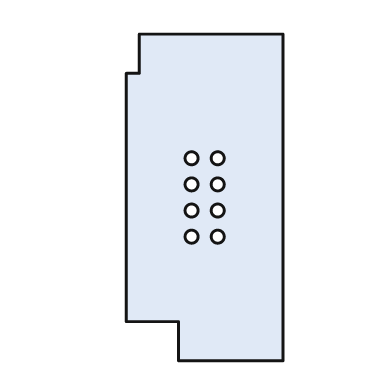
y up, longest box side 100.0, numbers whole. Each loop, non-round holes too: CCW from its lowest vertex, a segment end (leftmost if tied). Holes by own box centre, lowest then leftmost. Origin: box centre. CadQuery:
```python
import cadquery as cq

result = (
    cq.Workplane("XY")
    .moveTo(-8.0, -50.0)
    .lineTo(24.0, -50.0)
    .lineTo(24.0, 50.0)
    .lineTo(-20.0, 50.0)
    .lineTo(-20.0, 38.0)
    .lineTo(-24.0, 38.0)
    .lineTo(-24.0, -38.0)
    .lineTo(-8.0, -38.0)
    .close()
    .moveTo(-4.0, -12.0)
    .circle(2.0)
    .moveTo(4.0, -12.0)
    .circle(2.0)
    .moveTo(-4.0, -4.0)
    .circle(2.0)
    .moveTo(4.0, -4.0)
    .circle(2.0)
    .moveTo(-4.0, 4.0)
    .circle(2.0)
    .moveTo(4.0, 4.0)
    .circle(2.0)
    .moveTo(-4.0, 12.0)
    .circle(2.0)
    .moveTo(4.0, 12.0)
    .circle(2.0)
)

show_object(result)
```